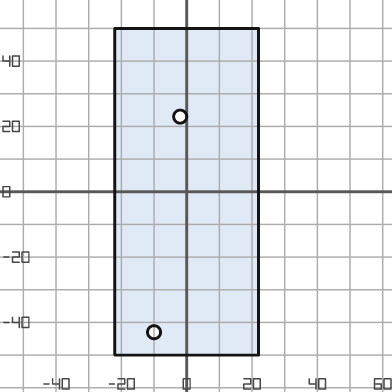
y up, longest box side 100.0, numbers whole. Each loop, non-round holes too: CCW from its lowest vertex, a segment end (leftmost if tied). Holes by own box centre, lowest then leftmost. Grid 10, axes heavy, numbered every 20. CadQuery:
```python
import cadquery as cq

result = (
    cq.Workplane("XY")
    .moveTo(-22.0, -50.0)
    .lineTo(22.0, -50.0)
    .lineTo(22.0, 50.0)
    .lineTo(-22.0, 50.0)
    .close()
    .moveTo(-10.0, -43.0)
    .circle(2.0)
    .moveTo(-2.0, 23.0)
    .circle(2.0)
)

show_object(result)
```